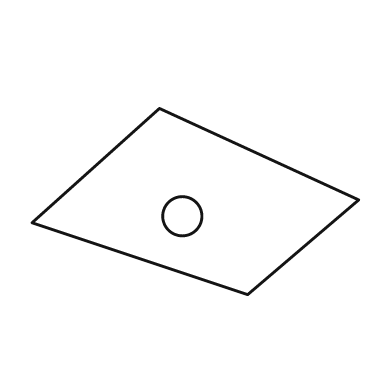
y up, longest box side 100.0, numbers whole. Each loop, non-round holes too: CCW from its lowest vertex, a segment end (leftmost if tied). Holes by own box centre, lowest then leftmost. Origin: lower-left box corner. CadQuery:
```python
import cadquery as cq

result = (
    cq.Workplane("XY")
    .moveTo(66.0, 0.0)
    .lineTo(100.0, 29.0)
    .lineTo(39.0, 57.0)
    .lineTo(0.0, 22.0)
    .close()
    .moveTo(46.0, 24.0)
    .circle(6.0)
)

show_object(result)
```